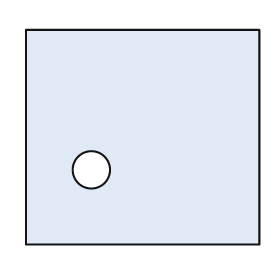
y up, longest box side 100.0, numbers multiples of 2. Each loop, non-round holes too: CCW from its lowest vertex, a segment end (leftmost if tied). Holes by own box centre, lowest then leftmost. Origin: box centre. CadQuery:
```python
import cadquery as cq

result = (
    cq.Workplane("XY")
    .moveTo(-50.0, -46.0)
    .lineTo(50.0, -46.0)
    .lineTo(50.0, 46.0)
    .lineTo(-50.0, 46.0)
    .close()
    .moveTo(-22.0, -14.0)
    .circle(8.0)
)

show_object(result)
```